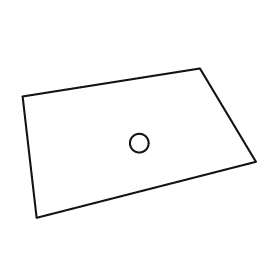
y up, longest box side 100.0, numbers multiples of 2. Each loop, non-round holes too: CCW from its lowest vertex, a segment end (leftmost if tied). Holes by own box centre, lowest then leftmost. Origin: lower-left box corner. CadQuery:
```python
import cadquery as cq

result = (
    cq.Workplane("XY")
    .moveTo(6.0, 0.0)
    .lineTo(100.0, 24.0)
    .lineTo(76.0, 64.0)
    .lineTo(0.0, 52.0)
    .close()
    .moveTo(50.0, 32.0)
    .circle(4.0)
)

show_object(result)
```